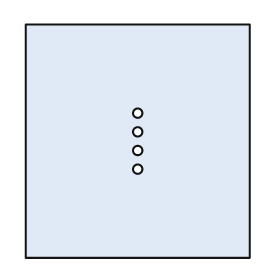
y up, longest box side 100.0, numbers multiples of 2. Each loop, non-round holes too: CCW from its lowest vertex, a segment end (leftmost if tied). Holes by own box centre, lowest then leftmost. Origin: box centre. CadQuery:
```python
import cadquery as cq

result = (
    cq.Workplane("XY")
    .moveTo(-48.0, -50.0)
    .lineTo(48.0, -50.0)
    .lineTo(48.0, 50.0)
    .lineTo(-48.0, 50.0)
    .close()
    .moveTo(0.0, -12.0)
    .circle(2.0)
    .moveTo(0.0, -4.0)
    .circle(2.0)
    .moveTo(0.0, 4.0)
    .circle(2.0)
    .moveTo(0.0, 12.0)
    .circle(2.0)
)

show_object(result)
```